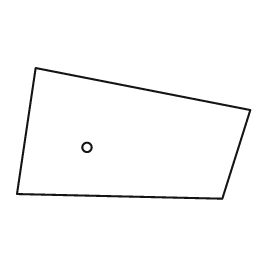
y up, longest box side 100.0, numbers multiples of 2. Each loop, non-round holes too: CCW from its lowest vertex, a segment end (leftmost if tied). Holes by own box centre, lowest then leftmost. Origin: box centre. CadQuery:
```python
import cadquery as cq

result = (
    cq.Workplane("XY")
    .moveTo(38.0, -28.0)
    .lineTo(50.0, 10.0)
    .lineTo(-42.0, 28.0)
    .lineTo(-50.0, -26.0)
    .close()
    .moveTo(-20.0, -6.0)
    .circle(2.0)
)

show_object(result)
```